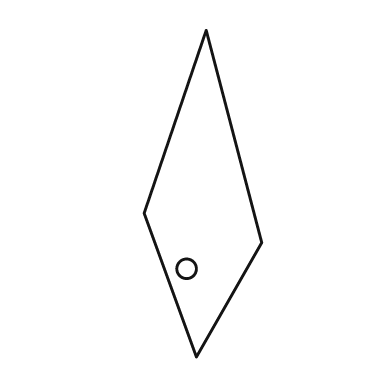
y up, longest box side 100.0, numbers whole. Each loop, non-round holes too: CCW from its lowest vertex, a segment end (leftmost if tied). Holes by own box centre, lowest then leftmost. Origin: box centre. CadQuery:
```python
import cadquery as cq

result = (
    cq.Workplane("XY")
    .moveTo(-2.0, -50.0)
    .lineTo(18.0, -15.0)
    .lineTo(1.0, 50.0)
    .lineTo(-18.0, -6.0)
    .close()
    .moveTo(-5.0, -23.0)
    .circle(3.0)
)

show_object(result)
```